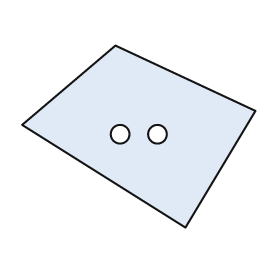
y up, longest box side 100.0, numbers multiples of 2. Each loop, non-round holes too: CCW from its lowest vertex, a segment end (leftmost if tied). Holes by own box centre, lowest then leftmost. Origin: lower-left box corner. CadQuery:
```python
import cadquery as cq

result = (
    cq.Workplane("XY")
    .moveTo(70.0, 0.0)
    .lineTo(100.0, 50.0)
    .lineTo(40.0, 78.0)
    .lineTo(0.0, 44.0)
    .close()
    .moveTo(42.0, 40.0)
    .circle(4.0)
    .moveTo(58.0, 40.0)
    .circle(4.0)
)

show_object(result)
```